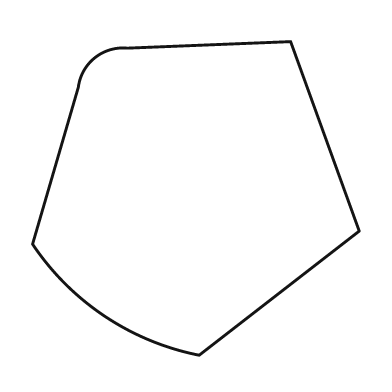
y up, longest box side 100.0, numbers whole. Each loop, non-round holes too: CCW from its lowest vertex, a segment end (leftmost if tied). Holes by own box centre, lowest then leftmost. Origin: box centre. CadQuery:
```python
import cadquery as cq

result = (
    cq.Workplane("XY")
    .moveTo(1.0, -48.0)
    .lineTo(50.0, -10.0)
    .lineTo(29.0, 48.0)
    .lineTo(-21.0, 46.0)
    .threePointArc((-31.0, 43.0), (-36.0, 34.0))
    .lineTo(-50.0, -14.0)
    .threePointArc((-28.0, -36.0), (1.0, -48.0))
    .close()
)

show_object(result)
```